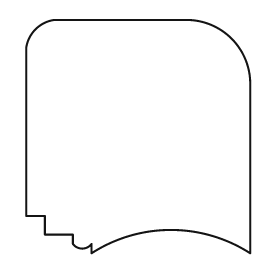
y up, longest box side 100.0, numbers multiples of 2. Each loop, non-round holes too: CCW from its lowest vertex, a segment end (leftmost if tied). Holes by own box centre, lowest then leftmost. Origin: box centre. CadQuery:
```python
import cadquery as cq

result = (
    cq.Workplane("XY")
    .moveTo(-20.0, -50.0)
    .threePointArc((14.0, -40.0), (48.0, -50.0))
    .lineTo(48.0, 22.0)
    .threePointArc((40.0, 42.0), (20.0, 50.0))
    .lineTo(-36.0, 50.0)
    .threePointArc((-44.0, 46.0), (-48.0, 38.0))
    .lineTo(-48.0, -34.0)
    .lineTo(-40.0, -34.0)
    .lineTo(-40.0, -42.0)
    .lineTo(-28.0, -42.0)
    .lineTo(-28.0, -46.0)
    .threePointArc((-24.0, -48.0), (-20.0, -46.0))
    .close()
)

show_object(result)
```